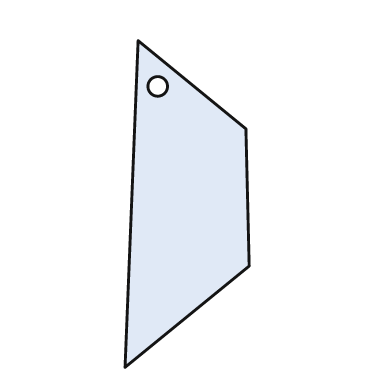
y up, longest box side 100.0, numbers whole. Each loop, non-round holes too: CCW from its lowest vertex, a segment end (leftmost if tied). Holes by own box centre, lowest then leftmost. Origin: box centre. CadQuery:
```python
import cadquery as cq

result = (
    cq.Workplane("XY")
    .moveTo(-19.0, -50.0)
    .lineTo(19.0, -19.0)
    .lineTo(18.0, 23.0)
    .lineTo(-15.0, 50.0)
    .close()
    .moveTo(-9.0, 36.0)
    .circle(3.0)
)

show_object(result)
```